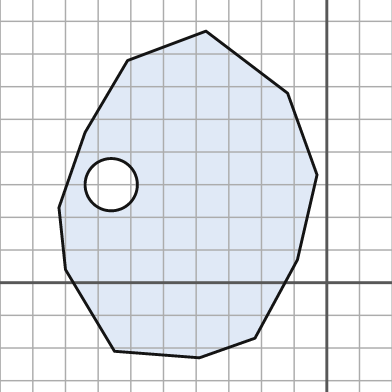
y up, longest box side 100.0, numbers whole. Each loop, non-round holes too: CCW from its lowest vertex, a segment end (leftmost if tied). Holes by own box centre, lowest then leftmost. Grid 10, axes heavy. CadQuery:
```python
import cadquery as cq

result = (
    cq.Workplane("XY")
    .moveTo(-39.0, -23.0)
    .lineTo(-22.0, -17.0)
    .lineTo(-9.0, 7.0)
    .lineTo(-3.0, 33.0)
    .lineTo(-12.0, 58.0)
    .lineTo(-37.0, 77.0)
    .lineTo(-61.0, 68.0)
    .lineTo(-74.0, 46.0)
    .lineTo(-82.0, 23.0)
    .lineTo(-80.0, 4.0)
    .lineTo(-65.0, -21.0)
    .close()
    .moveTo(-66.0, 30.0)
    .circle(8.0)
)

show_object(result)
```